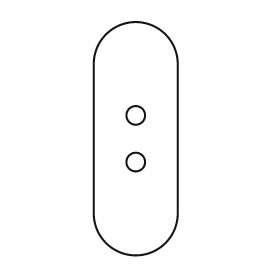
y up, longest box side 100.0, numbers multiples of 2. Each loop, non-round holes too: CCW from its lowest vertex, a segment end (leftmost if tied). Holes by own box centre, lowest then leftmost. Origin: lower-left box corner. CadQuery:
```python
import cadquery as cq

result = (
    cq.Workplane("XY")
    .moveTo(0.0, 18.0)
    .threePointArc((18.0, 0.0), (36.0, 18.0))
    .lineTo(36.0, 82.0)
    .threePointArc((18.0, 100.0), (0.0, 82.0))
    .close()
    .moveTo(18.0, 40.0)
    .circle(4.0)
    .moveTo(18.0, 60.0)
    .circle(4.0)
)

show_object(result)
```